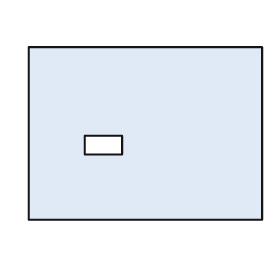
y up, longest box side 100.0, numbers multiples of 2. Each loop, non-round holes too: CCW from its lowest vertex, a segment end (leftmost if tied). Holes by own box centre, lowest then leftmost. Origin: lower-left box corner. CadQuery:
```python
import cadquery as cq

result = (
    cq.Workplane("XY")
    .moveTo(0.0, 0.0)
    .lineTo(100.0, 0.0)
    .lineTo(100.0, 74.0)
    .lineTo(0.0, 74.0)
    .close()
    .moveTo(24.0, 28.0)
    .lineTo(40.0, 28.0)
    .lineTo(40.0, 36.0)
    .lineTo(24.0, 36.0)
    .close()
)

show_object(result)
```